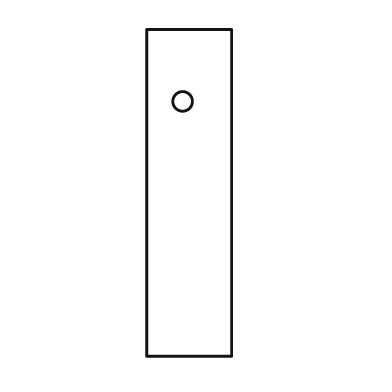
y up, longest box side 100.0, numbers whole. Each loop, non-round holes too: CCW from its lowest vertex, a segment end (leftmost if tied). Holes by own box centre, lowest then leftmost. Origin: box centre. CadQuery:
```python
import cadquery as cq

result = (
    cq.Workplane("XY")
    .moveTo(-13.0, -50.0)
    .lineTo(13.0, -50.0)
    .lineTo(13.0, 50.0)
    .lineTo(-13.0, 50.0)
    .close()
    .moveTo(-2.0, 28.0)
    .circle(3.0)
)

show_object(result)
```